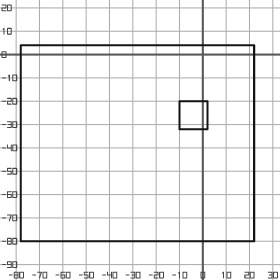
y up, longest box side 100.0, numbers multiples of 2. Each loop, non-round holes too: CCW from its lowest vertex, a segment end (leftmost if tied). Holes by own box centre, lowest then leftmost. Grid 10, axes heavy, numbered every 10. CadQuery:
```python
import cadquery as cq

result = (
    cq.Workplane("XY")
    .moveTo(-78.0, -80.0)
    .lineTo(22.0, -80.0)
    .lineTo(22.0, 4.0)
    .lineTo(-78.0, 4.0)
    .close()
    .moveTo(-10.0, -32.0)
    .lineTo(2.0, -32.0)
    .lineTo(2.0, -20.0)
    .lineTo(-10.0, -20.0)
    .close()
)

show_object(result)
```